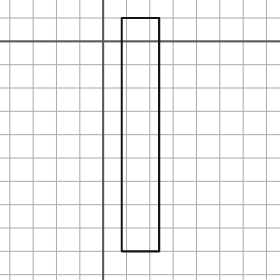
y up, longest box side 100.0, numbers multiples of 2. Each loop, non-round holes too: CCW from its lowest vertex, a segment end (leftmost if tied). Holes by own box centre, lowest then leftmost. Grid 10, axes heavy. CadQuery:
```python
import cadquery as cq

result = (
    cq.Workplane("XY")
    .moveTo(8.0, -90.0)
    .lineTo(24.0, -90.0)
    .lineTo(24.0, 10.0)
    .lineTo(8.0, 10.0)
    .close()
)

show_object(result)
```